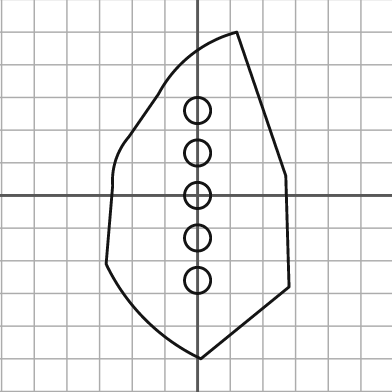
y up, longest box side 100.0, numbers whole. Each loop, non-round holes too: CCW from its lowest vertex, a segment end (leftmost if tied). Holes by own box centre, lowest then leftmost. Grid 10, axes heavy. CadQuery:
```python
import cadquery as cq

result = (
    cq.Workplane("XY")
    .moveTo(1.0, -50.0)
    .lineTo(28.0, -28.0)
    .lineTo(27.0, 6.0)
    .lineTo(12.0, 50.0)
    .threePointArc((-2.0, 43.0), (-12.0, 31.0))
    .lineTo(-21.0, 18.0)
    .threePointArc((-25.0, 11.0), (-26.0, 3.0))
    .lineTo(-28.0, -21.0)
    .threePointArc((-16.0, -38.0), (1.0, -50.0))
    .close()
    .moveTo(0.0, -26.0)
    .circle(4.0)
    .moveTo(0.0, -13.0)
    .circle(4.0)
    .moveTo(0.0, 0.0)
    .circle(4.0)
    .moveTo(0.0, 13.0)
    .circle(4.0)
    .moveTo(0.0, 26.0)
    .circle(4.0)
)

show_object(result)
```